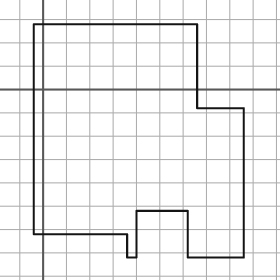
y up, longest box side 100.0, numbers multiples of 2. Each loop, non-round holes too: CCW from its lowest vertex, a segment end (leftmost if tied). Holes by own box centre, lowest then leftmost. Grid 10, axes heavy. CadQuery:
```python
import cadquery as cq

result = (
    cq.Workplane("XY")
    .moveTo(36.0, -72.0)
    .lineTo(40.0, -72.0)
    .lineTo(40.0, -52.0)
    .lineTo(62.0, -52.0)
    .lineTo(62.0, -72.0)
    .lineTo(86.0, -72.0)
    .lineTo(86.0, -8.0)
    .lineTo(66.0, -8.0)
    .lineTo(66.0, 28.0)
    .lineTo(-4.0, 28.0)
    .lineTo(-4.0, -62.0)
    .lineTo(36.0, -62.0)
    .close()
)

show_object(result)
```